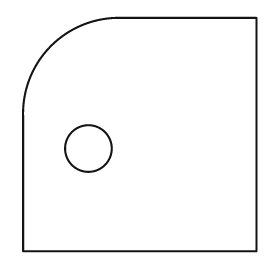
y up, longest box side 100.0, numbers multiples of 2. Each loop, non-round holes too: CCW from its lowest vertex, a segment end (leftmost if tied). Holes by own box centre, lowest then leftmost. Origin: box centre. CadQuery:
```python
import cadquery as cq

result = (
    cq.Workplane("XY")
    .moveTo(-50.0, -50.0)
    .lineTo(50.0, -50.0)
    .lineTo(50.0, 50.0)
    .lineTo(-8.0, 50.0)
    .threePointArc((-38.0, 38.0), (-50.0, 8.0))
    .close()
    .moveTo(-22.0, -6.0)
    .circle(10.0)
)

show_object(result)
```